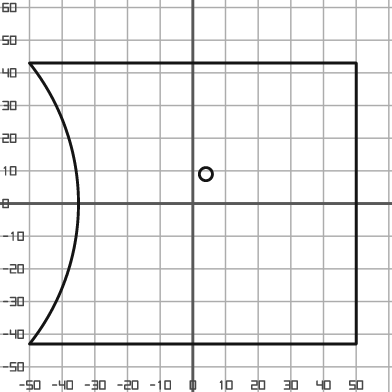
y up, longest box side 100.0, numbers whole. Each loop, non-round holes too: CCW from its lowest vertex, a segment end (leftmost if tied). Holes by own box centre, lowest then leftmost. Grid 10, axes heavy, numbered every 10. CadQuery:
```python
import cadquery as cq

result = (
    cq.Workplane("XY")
    .moveTo(-50.0, -43.0)
    .lineTo(50.0, -43.0)
    .lineTo(50.0, 43.0)
    .lineTo(-50.0, 43.0)
    .threePointArc((-35.0, 0.0), (-50.0, -43.0))
    .close()
    .moveTo(4.0, 9.0)
    .circle(2.0)
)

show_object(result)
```